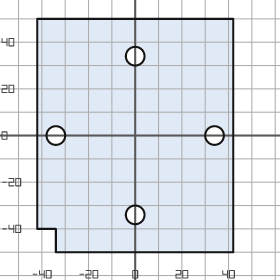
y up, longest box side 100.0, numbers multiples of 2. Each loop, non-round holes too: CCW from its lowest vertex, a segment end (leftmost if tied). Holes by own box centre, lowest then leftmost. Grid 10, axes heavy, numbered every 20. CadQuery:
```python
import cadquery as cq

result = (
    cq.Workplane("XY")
    .moveTo(-34.0, -50.0)
    .lineTo(42.0, -50.0)
    .lineTo(42.0, 50.0)
    .lineTo(-42.0, 50.0)
    .lineTo(-42.0, -40.0)
    .lineTo(-34.0, -40.0)
    .close()
    .moveTo(0.0, -34.0)
    .circle(4.0)
    .moveTo(-34.0, 0.0)
    .circle(4.0)
    .moveTo(34.0, 0.0)
    .circle(4.0)
    .moveTo(0.0, 34.0)
    .circle(4.0)
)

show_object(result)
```